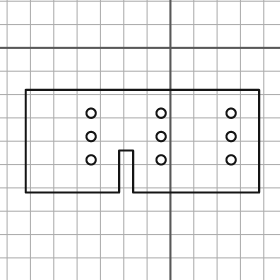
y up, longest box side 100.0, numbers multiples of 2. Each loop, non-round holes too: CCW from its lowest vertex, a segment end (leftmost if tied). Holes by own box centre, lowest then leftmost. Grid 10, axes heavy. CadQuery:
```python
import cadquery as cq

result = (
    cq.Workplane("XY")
    .moveTo(-62.0, -62.0)
    .lineTo(-22.0, -62.0)
    .lineTo(-22.0, -44.0)
    .lineTo(-16.0, -44.0)
    .lineTo(-16.0, -62.0)
    .lineTo(38.0, -62.0)
    .lineTo(38.0, -18.0)
    .lineTo(-62.0, -18.0)
    .close()
    .moveTo(-34.0, -48.0)
    .circle(2.0)
    .moveTo(-4.0, -48.0)
    .circle(2.0)
    .moveTo(26.0, -48.0)
    .circle(2.0)
    .moveTo(-34.0, -38.0)
    .circle(2.0)
    .moveTo(-4.0, -38.0)
    .circle(2.0)
    .moveTo(26.0, -38.0)
    .circle(2.0)
    .moveTo(-34.0, -28.0)
    .circle(2.0)
    .moveTo(-4.0, -28.0)
    .circle(2.0)
    .moveTo(26.0, -28.0)
    .circle(2.0)
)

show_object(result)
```